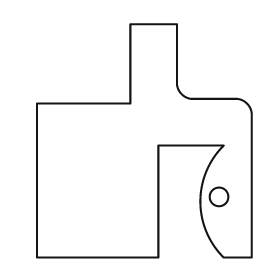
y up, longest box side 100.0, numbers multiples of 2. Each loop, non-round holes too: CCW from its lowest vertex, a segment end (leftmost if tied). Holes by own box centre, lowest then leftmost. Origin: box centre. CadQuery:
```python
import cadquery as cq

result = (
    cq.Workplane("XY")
    .moveTo(-46.0, -50.0)
    .lineTo(6.0, -50.0)
    .lineTo(6.0, -2.0)
    .lineTo(34.0, -2.0)
    .threePointArc((24.0, -26.0), (34.0, -50.0))
    .lineTo(46.0, -50.0)
    .lineTo(46.0, 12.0)
    .threePointArc((44.0, 16.0), (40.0, 18.0))
    .lineTo(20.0, 18.0)
    .threePointArc((16.0, 20.0), (14.0, 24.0))
    .lineTo(14.0, 50.0)
    .lineTo(-6.0, 50.0)
    .lineTo(-6.0, 16.0)
    .lineTo(-46.0, 16.0)
    .close()
    .moveTo(32.0, -24.0)
    .circle(4.0)
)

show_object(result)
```